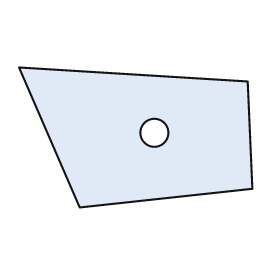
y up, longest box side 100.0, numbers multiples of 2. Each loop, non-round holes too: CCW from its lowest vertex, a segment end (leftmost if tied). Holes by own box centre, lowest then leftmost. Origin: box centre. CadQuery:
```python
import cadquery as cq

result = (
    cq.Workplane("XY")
    .moveTo(-24.0, -30.0)
    .lineTo(50.0, -22.0)
    .lineTo(48.0, 24.0)
    .lineTo(-50.0, 30.0)
    .close()
    .moveTo(8.0, 2.0)
    .circle(6.0)
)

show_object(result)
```